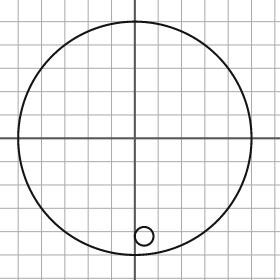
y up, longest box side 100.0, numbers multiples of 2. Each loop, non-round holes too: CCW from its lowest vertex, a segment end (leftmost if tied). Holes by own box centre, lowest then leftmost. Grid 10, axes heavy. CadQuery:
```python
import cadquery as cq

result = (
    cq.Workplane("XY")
    .moveTo(0.0, 0.0)
    .circle(50.0)
    .moveTo(4.0, -42.0)
    .circle(4.0)
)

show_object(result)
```